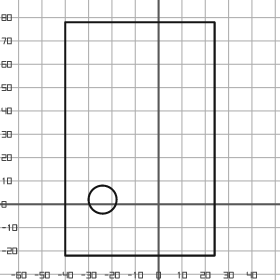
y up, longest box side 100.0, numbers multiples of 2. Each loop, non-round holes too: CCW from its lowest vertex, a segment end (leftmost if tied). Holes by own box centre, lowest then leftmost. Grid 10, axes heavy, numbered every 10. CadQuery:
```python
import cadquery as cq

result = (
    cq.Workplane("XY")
    .moveTo(-40.0, -22.0)
    .lineTo(24.0, -22.0)
    .lineTo(24.0, 78.0)
    .lineTo(-40.0, 78.0)
    .close()
    .moveTo(-24.0, 2.0)
    .circle(6.0)
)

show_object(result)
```